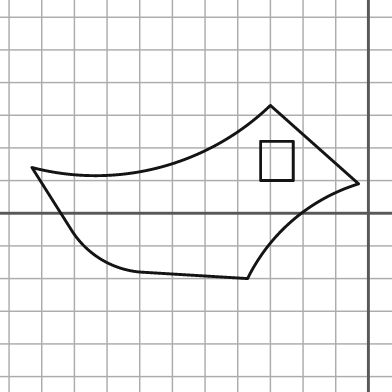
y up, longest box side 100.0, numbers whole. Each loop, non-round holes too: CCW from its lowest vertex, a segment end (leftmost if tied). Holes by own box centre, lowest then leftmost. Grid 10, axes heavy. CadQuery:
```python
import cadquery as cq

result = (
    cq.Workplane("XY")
    .moveTo(-37.0, -20.0)
    .threePointArc((-23.0, -2.0), (-3.0, 9.0))
    .lineTo(-30.0, 33.0)
    .threePointArc((-64.0, 14.0), (-103.0, 14.0))
    .lineTo(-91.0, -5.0)
    .threePointArc((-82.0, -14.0), (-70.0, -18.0))
    .close()
    .moveTo(-33.0, 10.0)
    .lineTo(-23.0, 10.0)
    .lineTo(-23.0, 22.0)
    .lineTo(-33.0, 22.0)
    .close()
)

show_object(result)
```